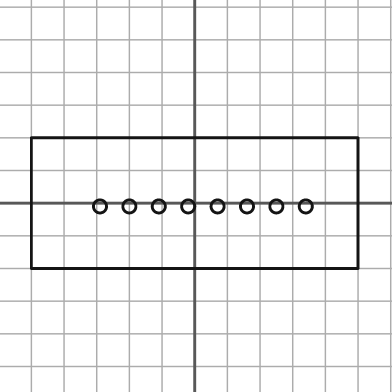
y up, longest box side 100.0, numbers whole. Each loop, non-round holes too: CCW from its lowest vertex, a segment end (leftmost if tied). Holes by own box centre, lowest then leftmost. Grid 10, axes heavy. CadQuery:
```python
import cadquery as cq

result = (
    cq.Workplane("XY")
    .moveTo(-50.0, -20.0)
    .lineTo(50.0, -20.0)
    .lineTo(50.0, 20.0)
    .lineTo(-50.0, 20.0)
    .close()
    .moveTo(-29.0, -1.0)
    .circle(2.0)
    .moveTo(-20.0, -1.0)
    .circle(2.0)
    .moveTo(-11.0, -1.0)
    .circle(2.0)
    .moveTo(-2.0, -1.0)
    .circle(2.0)
    .moveTo(7.0, -1.0)
    .circle(2.0)
    .moveTo(16.0, -1.0)
    .circle(2.0)
    .moveTo(25.0, -1.0)
    .circle(2.0)
    .moveTo(34.0, -1.0)
    .circle(2.0)
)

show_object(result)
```